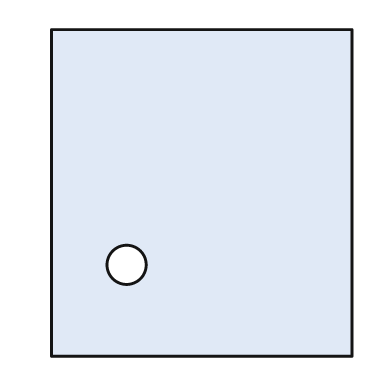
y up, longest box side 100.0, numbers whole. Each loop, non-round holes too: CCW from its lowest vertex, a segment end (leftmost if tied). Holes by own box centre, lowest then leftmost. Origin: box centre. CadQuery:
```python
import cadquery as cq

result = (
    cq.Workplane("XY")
    .moveTo(-46.0, -50.0)
    .lineTo(46.0, -50.0)
    .lineTo(46.0, 50.0)
    .lineTo(-46.0, 50.0)
    .close()
    .moveTo(-23.0, -22.0)
    .circle(6.0)
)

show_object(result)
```